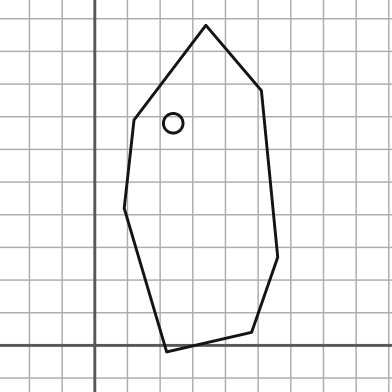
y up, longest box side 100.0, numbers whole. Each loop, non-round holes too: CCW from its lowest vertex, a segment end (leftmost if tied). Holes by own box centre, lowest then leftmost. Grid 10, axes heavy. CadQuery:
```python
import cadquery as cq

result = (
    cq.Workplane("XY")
    .moveTo(22.0, -2.0)
    .lineTo(48.0, 4.0)
    .lineTo(56.0, 27.0)
    .lineTo(51.0, 78.0)
    .lineTo(34.0, 98.0)
    .lineTo(12.0, 69.0)
    .lineTo(9.0, 42.0)
    .close()
    .moveTo(24.0, 68.0)
    .circle(3.0)
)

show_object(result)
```